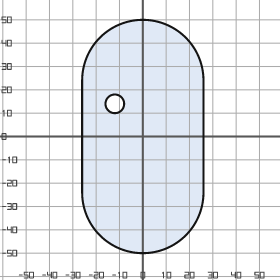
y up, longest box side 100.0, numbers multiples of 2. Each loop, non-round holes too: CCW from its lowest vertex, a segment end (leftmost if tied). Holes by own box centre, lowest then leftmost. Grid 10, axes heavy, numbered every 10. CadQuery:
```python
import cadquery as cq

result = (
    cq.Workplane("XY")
    .moveTo(-26.0, -24.0)
    .threePointArc((0.0, -50.0), (26.0, -24.0))
    .lineTo(26.0, 24.0)
    .threePointArc((0.0, 50.0), (-26.0, 24.0))
    .close()
    .moveTo(-12.0, 14.0)
    .circle(4.0)
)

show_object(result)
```